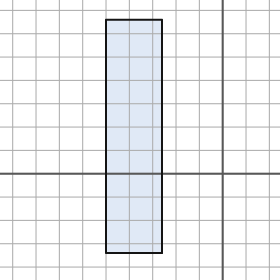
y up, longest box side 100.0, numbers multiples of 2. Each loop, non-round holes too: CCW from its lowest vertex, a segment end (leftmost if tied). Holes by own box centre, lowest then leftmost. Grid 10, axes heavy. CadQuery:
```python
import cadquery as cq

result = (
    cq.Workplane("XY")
    .moveTo(-50.0, -34.0)
    .lineTo(-26.0, -34.0)
    .lineTo(-26.0, 66.0)
    .lineTo(-50.0, 66.0)
    .close()
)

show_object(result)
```